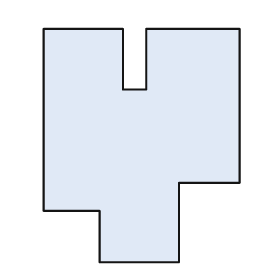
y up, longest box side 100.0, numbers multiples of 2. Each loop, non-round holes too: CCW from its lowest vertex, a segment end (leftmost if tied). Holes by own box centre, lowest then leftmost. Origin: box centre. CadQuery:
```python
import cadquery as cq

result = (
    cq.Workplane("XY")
    .moveTo(-18.0, -50.0)
    .lineTo(16.0, -50.0)
    .lineTo(16.0, -16.0)
    .lineTo(42.0, -16.0)
    .lineTo(42.0, 50.0)
    .lineTo(2.0, 50.0)
    .lineTo(2.0, 24.0)
    .lineTo(-8.0, 24.0)
    .lineTo(-8.0, 50.0)
    .lineTo(-42.0, 50.0)
    .lineTo(-42.0, -28.0)
    .lineTo(-18.0, -28.0)
    .close()
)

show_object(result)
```